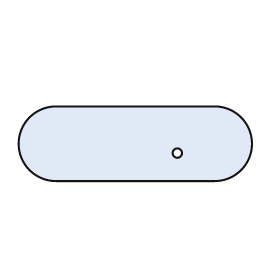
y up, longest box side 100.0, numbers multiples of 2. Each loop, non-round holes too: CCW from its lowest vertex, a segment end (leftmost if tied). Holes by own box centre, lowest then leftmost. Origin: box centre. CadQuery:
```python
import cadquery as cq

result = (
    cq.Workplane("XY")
    .moveTo(-34.0, -16.0)
    .lineTo(34.0, -16.0)
    .threePointArc((50.0, 0.0), (34.0, 16.0))
    .lineTo(-34.0, 16.0)
    .threePointArc((-50.0, 0.0), (-34.0, -16.0))
    .close()
    .moveTo(18.0, -4.0)
    .circle(2.0)
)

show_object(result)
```